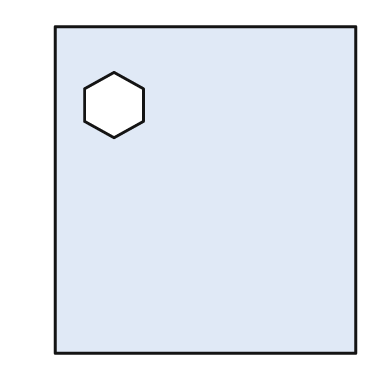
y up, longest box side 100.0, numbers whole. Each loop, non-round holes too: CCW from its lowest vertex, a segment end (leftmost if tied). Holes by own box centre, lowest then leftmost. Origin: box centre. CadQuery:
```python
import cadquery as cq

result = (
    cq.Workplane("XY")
    .moveTo(-46.0, -50.0)
    .lineTo(46.0, -50.0)
    .lineTo(46.0, 50.0)
    .lineTo(-46.0, 50.0)
    .close()
    .moveTo(-28.0, 16.0)
    .lineTo(-19.0, 21.0)
    .lineTo(-19.0, 31.0)
    .lineTo(-28.0, 36.0)
    .lineTo(-37.0, 31.0)
    .lineTo(-37.0, 21.0)
    .close()
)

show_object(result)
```